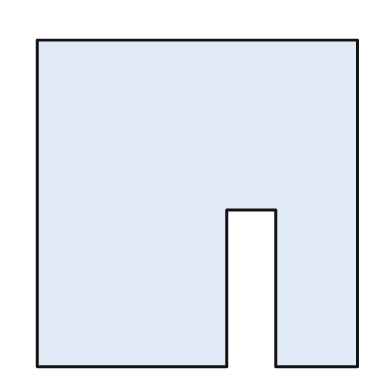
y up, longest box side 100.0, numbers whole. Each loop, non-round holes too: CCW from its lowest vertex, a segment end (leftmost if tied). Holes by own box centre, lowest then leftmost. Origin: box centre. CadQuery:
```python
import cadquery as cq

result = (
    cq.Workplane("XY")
    .moveTo(-49.0, -50.0)
    .lineTo(9.0, -50.0)
    .lineTo(9.0, -2.0)
    .lineTo(24.0, -2.0)
    .lineTo(24.0, -50.0)
    .lineTo(49.0, -50.0)
    .lineTo(49.0, 50.0)
    .lineTo(-49.0, 50.0)
    .close()
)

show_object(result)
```